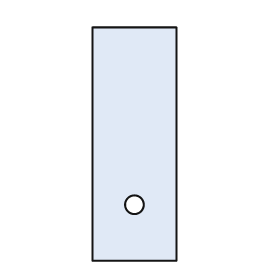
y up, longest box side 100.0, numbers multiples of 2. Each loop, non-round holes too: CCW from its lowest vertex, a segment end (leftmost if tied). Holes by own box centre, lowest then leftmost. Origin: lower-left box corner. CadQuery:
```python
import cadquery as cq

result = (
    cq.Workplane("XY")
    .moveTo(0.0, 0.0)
    .lineTo(36.0, 0.0)
    .lineTo(36.0, 100.0)
    .lineTo(0.0, 100.0)
    .close()
    .moveTo(18.0, 24.0)
    .circle(4.0)
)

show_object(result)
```